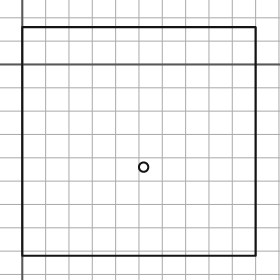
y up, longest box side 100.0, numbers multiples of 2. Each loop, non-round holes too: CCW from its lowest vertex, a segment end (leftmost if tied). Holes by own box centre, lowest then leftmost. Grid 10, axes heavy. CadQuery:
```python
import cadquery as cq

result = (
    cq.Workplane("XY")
    .moveTo(0.0, -82.0)
    .lineTo(100.0, -82.0)
    .lineTo(100.0, 16.0)
    .lineTo(0.0, 16.0)
    .close()
    .moveTo(52.0, -44.0)
    .circle(2.0)
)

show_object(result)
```